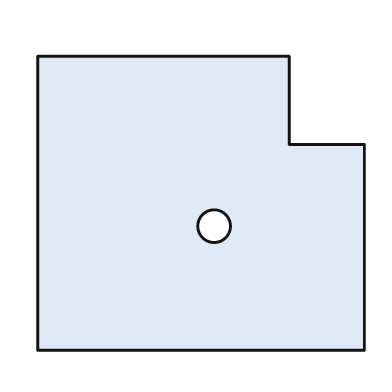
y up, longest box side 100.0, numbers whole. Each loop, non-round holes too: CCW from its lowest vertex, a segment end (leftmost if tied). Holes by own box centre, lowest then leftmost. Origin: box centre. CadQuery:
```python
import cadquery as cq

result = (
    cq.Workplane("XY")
    .moveTo(-50.0, -45.0)
    .lineTo(50.0, -45.0)
    .lineTo(50.0, 18.0)
    .lineTo(27.0, 18.0)
    .lineTo(27.0, 45.0)
    .lineTo(-50.0, 45.0)
    .close()
    .moveTo(4.0, -7.0)
    .circle(5.0)
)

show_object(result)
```